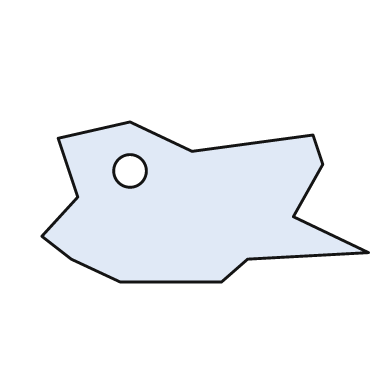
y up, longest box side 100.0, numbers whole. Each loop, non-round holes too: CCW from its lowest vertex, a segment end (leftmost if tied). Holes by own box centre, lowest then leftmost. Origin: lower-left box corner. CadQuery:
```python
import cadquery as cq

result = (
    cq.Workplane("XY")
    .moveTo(24.0, 0.0)
    .lineTo(55.0, 0.0)
    .lineTo(63.0, 7.0)
    .lineTo(100.0, 9.0)
    .lineTo(77.0, 20.0)
    .lineTo(86.0, 36.0)
    .lineTo(83.0, 45.0)
    .lineTo(46.0, 40.0)
    .lineTo(27.0, 49.0)
    .lineTo(5.0, 44.0)
    .lineTo(11.0, 26.0)
    .lineTo(0.0, 14.0)
    .lineTo(9.0, 7.0)
    .close()
    .moveTo(27.0, 34.0)
    .circle(5.0)
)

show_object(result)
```